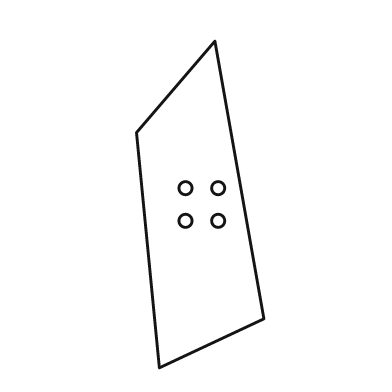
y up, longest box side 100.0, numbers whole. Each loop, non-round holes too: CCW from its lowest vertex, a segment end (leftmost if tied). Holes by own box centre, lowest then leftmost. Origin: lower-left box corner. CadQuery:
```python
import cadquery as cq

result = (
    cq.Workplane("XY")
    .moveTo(7.0, 0.0)
    .lineTo(39.0, 15.0)
    .lineTo(24.0, 100.0)
    .lineTo(0.0, 72.0)
    .close()
    .moveTo(15.0, 45.0)
    .circle(2.0)
    .moveTo(25.0, 45.0)
    .circle(2.0)
    .moveTo(15.0, 55.0)
    .circle(2.0)
    .moveTo(25.0, 55.0)
    .circle(2.0)
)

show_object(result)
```